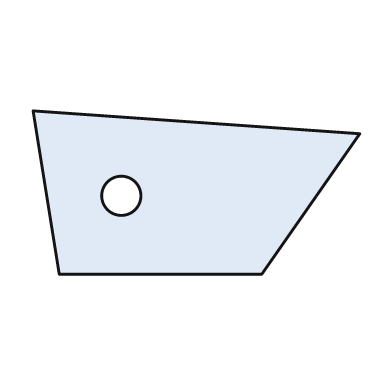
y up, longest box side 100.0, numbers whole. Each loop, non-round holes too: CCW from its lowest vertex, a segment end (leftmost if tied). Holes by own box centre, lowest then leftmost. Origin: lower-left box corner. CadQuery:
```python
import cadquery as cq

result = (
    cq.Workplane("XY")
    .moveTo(8.0, 0.0)
    .lineTo(70.0, 0.0)
    .lineTo(100.0, 43.0)
    .lineTo(0.0, 50.0)
    .close()
    .moveTo(27.0, 24.0)
    .circle(6.0)
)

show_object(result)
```